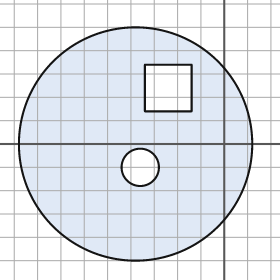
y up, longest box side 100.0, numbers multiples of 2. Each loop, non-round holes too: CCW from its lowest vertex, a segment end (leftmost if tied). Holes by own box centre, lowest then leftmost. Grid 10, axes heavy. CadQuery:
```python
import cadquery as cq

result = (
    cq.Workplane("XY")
    .moveTo(-38.0, 0.0)
    .circle(50.0)
    .moveTo(-36.0, -10.0)
    .circle(8.0)
    .moveTo(-34.0, 14.0)
    .lineTo(-14.0, 14.0)
    .lineTo(-14.0, 34.0)
    .lineTo(-34.0, 34.0)
    .close()
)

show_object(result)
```